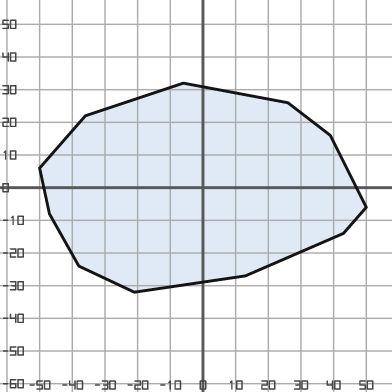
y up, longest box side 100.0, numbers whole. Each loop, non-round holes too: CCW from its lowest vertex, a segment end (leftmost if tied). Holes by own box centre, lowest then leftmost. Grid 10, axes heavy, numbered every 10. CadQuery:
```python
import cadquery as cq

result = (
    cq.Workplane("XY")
    .moveTo(-21.0, -32.0)
    .lineTo(13.0, -27.0)
    .lineTo(43.0, -14.0)
    .lineTo(50.0, -6.0)
    .lineTo(39.0, 16.0)
    .lineTo(26.0, 26.0)
    .lineTo(-6.0, 32.0)
    .lineTo(-36.0, 22.0)
    .lineTo(-50.0, 6.0)
    .lineTo(-47.0, -8.0)
    .lineTo(-38.0, -24.0)
    .close()
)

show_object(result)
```